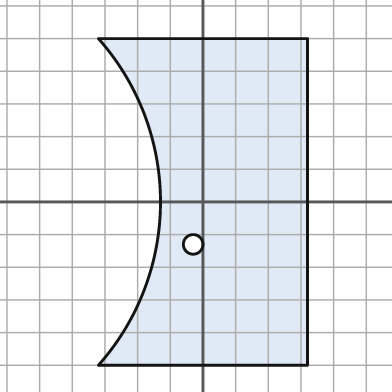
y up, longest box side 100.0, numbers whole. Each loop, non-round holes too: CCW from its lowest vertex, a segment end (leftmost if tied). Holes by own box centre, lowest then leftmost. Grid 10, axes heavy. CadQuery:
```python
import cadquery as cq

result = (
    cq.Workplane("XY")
    .moveTo(-32.0, -50.0)
    .lineTo(32.0, -50.0)
    .lineTo(32.0, 50.0)
    .lineTo(-32.0, 50.0)
    .threePointArc((-13.0, 0.0), (-32.0, -50.0))
    .close()
    .moveTo(-3.0, -13.0)
    .circle(3.0)
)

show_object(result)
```